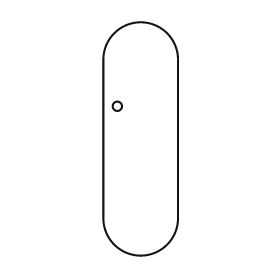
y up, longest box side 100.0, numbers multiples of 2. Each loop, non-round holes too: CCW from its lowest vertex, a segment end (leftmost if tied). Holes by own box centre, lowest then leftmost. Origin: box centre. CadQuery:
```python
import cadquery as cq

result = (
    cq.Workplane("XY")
    .moveTo(-16.0, -34.0)
    .threePointArc((0.0, -50.0), (16.0, -34.0))
    .lineTo(16.0, 34.0)
    .threePointArc((0.0, 50.0), (-16.0, 34.0))
    .close()
    .moveTo(-10.0, 14.0)
    .circle(2.0)
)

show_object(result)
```